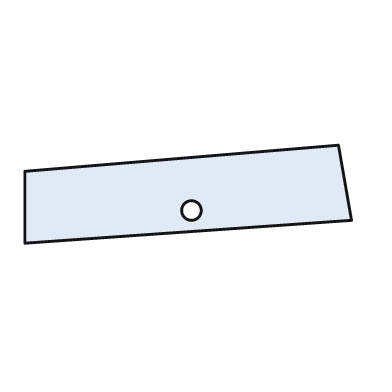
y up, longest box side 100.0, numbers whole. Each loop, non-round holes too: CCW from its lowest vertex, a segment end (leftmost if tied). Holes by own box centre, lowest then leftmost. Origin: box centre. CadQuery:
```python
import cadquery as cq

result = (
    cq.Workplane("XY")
    .moveTo(-50.0, -15.0)
    .lineTo(50.0, -8.0)
    .lineTo(46.0, 15.0)
    .lineTo(-50.0, 7.0)
    .close()
    .moveTo(1.0, -5.0)
    .circle(3.0)
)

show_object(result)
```